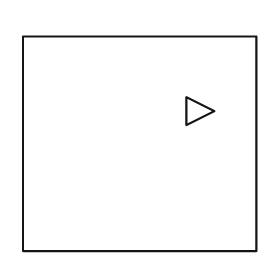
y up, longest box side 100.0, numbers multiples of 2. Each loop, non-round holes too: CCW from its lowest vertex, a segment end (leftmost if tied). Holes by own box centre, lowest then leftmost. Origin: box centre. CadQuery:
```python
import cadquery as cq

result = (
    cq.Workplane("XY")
    .moveTo(-50.0, -46.0)
    .lineTo(50.0, -46.0)
    .lineTo(50.0, 46.0)
    .lineTo(-50.0, 46.0)
    .close()
    .moveTo(20.0, 8.0)
    .lineTo(32.0, 14.0)
    .lineTo(20.0, 20.0)
    .close()
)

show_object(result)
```